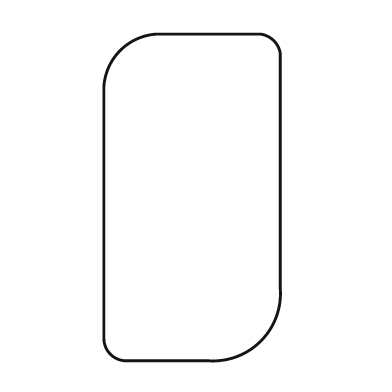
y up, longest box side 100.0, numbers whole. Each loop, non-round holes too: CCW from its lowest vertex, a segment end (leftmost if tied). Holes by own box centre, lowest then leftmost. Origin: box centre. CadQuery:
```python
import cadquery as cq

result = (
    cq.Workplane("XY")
    .moveTo(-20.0, -50.0)
    .lineTo(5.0, -50.0)
    .threePointArc((21.0, -44.0), (27.0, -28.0))
    .lineTo(27.0, 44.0)
    .threePointArc((25.0, 48.0), (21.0, 50.0))
    .lineTo(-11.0, 50.0)
    .threePointArc((-22.0, 45.0), (-27.0, 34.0))
    .lineTo(-27.0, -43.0)
    .threePointArc((-25.0, -48.0), (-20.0, -50.0))
    .close()
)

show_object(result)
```